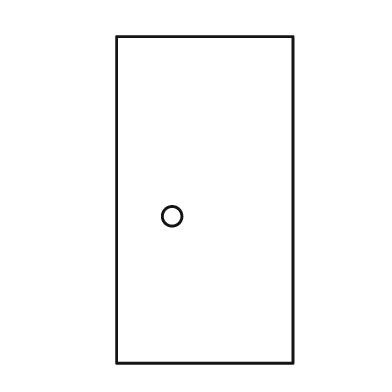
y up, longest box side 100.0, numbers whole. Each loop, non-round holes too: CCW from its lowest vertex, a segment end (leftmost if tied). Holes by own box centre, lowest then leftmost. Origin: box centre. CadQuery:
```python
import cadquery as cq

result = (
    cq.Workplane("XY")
    .moveTo(-27.0, -50.0)
    .lineTo(27.0, -50.0)
    .lineTo(27.0, 50.0)
    .lineTo(-27.0, 50.0)
    .close()
    .moveTo(-10.0, -5.0)
    .circle(3.0)
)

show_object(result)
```